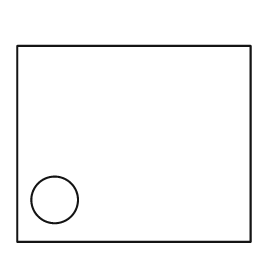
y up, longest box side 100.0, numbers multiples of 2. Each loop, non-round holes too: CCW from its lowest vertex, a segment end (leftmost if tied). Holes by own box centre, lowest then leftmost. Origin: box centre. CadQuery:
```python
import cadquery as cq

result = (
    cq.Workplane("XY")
    .moveTo(-50.0, -42.0)
    .lineTo(50.0, -42.0)
    .lineTo(50.0, 42.0)
    .lineTo(-50.0, 42.0)
    .close()
    .moveTo(-34.0, -24.0)
    .circle(10.0)
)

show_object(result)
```